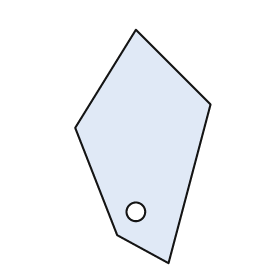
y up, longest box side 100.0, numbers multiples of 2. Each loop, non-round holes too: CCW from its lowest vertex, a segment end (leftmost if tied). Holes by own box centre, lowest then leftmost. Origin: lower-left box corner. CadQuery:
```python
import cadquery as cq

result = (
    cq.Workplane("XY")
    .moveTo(40.0, 0.0)
    .lineTo(58.0, 68.0)
    .lineTo(26.0, 100.0)
    .lineTo(0.0, 58.0)
    .lineTo(18.0, 12.0)
    .close()
    .moveTo(26.0, 22.0)
    .circle(4.0)
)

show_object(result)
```